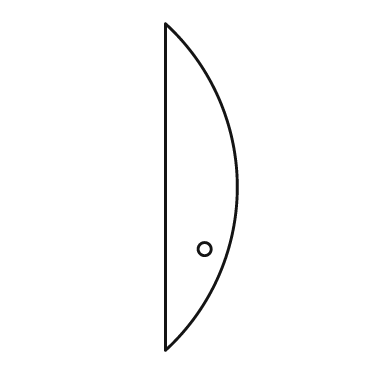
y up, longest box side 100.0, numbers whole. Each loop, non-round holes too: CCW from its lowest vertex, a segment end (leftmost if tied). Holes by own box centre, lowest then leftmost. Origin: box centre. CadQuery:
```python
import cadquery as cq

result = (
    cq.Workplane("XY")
    .moveTo(-11.0, -50.0)
    .threePointArc((11.0, 0.0), (-11.0, 50.0))
    .close()
    .moveTo(1.0, -19.0)
    .circle(2.0)
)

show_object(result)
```